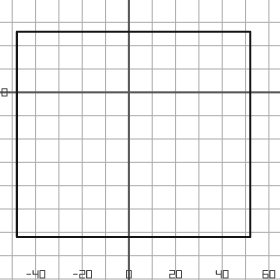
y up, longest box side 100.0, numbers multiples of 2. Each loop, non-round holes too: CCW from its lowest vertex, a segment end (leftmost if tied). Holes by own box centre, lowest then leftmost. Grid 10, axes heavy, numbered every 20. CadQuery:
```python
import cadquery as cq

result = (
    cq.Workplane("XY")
    .moveTo(-48.0, -62.0)
    .lineTo(52.0, -62.0)
    .lineTo(52.0, 26.0)
    .lineTo(-48.0, 26.0)
    .close()
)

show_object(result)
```